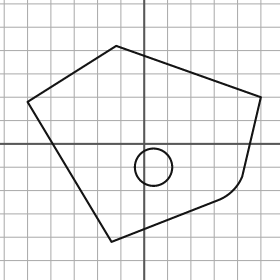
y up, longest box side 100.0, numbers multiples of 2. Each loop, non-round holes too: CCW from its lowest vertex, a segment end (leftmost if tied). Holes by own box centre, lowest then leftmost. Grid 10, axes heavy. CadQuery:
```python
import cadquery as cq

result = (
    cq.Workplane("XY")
    .moveTo(-14.0, -42.0)
    .lineTo(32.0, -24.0)
    .threePointArc((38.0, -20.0), (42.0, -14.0))
    .lineTo(50.0, 20.0)
    .lineTo(-12.0, 42.0)
    .lineTo(-50.0, 18.0)
    .close()
    .moveTo(4.0, -10.0)
    .circle(8.0)
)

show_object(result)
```